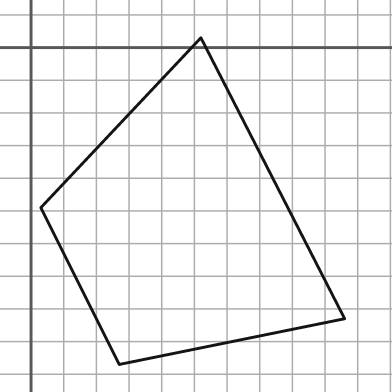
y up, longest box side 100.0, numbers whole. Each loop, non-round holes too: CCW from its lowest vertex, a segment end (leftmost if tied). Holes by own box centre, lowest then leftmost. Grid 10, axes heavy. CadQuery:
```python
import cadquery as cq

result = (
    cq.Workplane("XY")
    .moveTo(27.0, -97.0)
    .lineTo(96.0, -83.0)
    .lineTo(52.0, 3.0)
    .lineTo(3.0, -49.0)
    .close()
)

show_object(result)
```